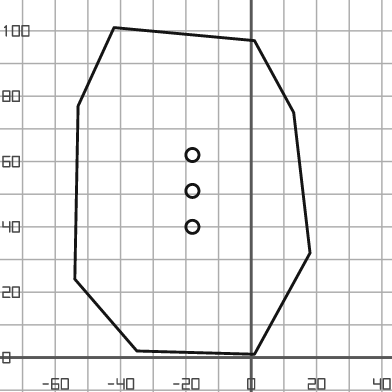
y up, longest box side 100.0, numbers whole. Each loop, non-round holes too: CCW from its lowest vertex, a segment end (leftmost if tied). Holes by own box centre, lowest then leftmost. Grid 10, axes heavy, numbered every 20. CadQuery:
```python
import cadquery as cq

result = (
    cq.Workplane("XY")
    .moveTo(1.0, 1.0)
    .lineTo(18.0, 32.0)
    .lineTo(13.0, 75.0)
    .lineTo(1.0, 97.0)
    .lineTo(-42.0, 101.0)
    .lineTo(-53.0, 77.0)
    .lineTo(-54.0, 24.0)
    .lineTo(-35.0, 2.0)
    .close()
    .moveTo(-18.0, 40.0)
    .circle(2.0)
    .moveTo(-18.0, 51.0)
    .circle(2.0)
    .moveTo(-18.0, 62.0)
    .circle(2.0)
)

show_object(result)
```